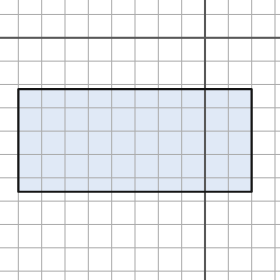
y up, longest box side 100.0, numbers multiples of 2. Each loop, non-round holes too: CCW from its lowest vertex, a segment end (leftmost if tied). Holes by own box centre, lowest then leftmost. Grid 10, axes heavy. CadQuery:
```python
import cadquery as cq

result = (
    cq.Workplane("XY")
    .moveTo(-80.0, -66.0)
    .lineTo(20.0, -66.0)
    .lineTo(20.0, -22.0)
    .lineTo(-80.0, -22.0)
    .close()
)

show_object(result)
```